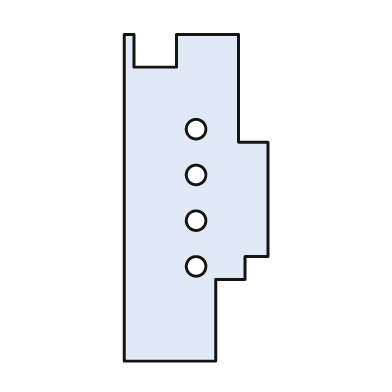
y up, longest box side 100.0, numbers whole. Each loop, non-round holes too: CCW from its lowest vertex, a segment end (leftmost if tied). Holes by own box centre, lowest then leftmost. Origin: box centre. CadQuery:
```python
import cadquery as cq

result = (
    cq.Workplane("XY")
    .moveTo(-22.0, -50.0)
    .lineTo(6.0, -50.0)
    .lineTo(6.0, -25.0)
    .lineTo(15.0, -25.0)
    .lineTo(15.0, -18.0)
    .lineTo(22.0, -18.0)
    .lineTo(22.0, 17.0)
    .lineTo(13.0, 17.0)
    .lineTo(13.0, 50.0)
    .lineTo(-6.0, 50.0)
    .lineTo(-6.0, 40.0)
    .lineTo(-19.0, 40.0)
    .lineTo(-19.0, 50.0)
    .lineTo(-22.0, 50.0)
    .close()
    .moveTo(0.0, -21.0)
    .circle(3.0)
    .moveTo(0.0, -7.0)
    .circle(3.0)
    .moveTo(0.0, 7.0)
    .circle(3.0)
    .moveTo(0.0, 21.0)
    .circle(3.0)
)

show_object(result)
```